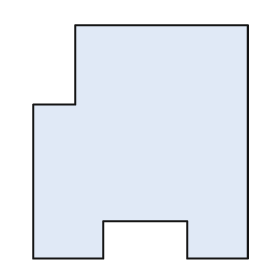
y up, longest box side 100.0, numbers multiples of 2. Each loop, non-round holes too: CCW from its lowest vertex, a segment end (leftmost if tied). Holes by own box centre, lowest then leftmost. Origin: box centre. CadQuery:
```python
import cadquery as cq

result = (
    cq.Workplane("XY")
    .moveTo(-46.0, -50.0)
    .lineTo(-16.0, -50.0)
    .lineTo(-16.0, -34.0)
    .lineTo(20.0, -34.0)
    .lineTo(20.0, -50.0)
    .lineTo(46.0, -50.0)
    .lineTo(46.0, 50.0)
    .lineTo(-28.0, 50.0)
    .lineTo(-28.0, 16.0)
    .lineTo(-46.0, 16.0)
    .close()
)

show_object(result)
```